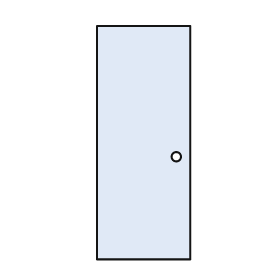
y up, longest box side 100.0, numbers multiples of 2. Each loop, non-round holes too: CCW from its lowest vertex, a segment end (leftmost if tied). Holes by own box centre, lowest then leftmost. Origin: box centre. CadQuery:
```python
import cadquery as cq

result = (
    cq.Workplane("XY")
    .moveTo(-20.0, -50.0)
    .lineTo(20.0, -50.0)
    .lineTo(20.0, 50.0)
    .lineTo(-20.0, 50.0)
    .close()
    .moveTo(14.0, -6.0)
    .circle(2.0)
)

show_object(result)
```